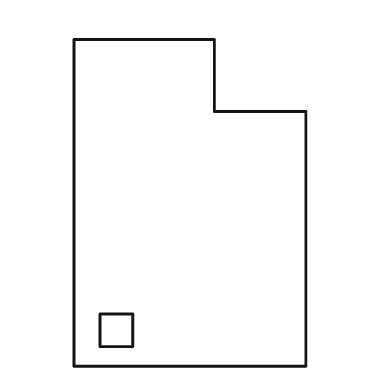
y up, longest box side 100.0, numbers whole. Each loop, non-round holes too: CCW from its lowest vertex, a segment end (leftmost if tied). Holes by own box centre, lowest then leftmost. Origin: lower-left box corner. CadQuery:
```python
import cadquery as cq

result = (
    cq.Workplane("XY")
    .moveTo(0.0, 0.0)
    .lineTo(71.0, 0.0)
    .lineTo(71.0, 78.0)
    .lineTo(43.0, 78.0)
    .lineTo(43.0, 100.0)
    .lineTo(0.0, 100.0)
    .close()
    .moveTo(8.0, 6.0)
    .lineTo(18.0, 6.0)
    .lineTo(18.0, 16.0)
    .lineTo(8.0, 16.0)
    .close()
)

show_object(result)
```